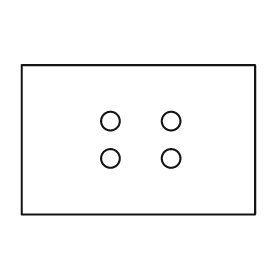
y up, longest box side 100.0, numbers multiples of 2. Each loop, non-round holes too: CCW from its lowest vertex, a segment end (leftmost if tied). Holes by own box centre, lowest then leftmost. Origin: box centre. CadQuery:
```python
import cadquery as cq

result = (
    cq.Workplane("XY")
    .moveTo(-50.0, -32.0)
    .lineTo(50.0, -32.0)
    .lineTo(50.0, 32.0)
    .lineTo(-50.0, 32.0)
    .close()
    .moveTo(-12.0, -8.0)
    .circle(4.0)
    .moveTo(14.0, -8.0)
    .circle(4.0)
    .moveTo(-12.0, 8.0)
    .circle(4.0)
    .moveTo(14.0, 8.0)
    .circle(4.0)
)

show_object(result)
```